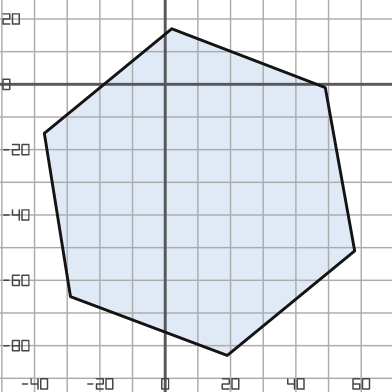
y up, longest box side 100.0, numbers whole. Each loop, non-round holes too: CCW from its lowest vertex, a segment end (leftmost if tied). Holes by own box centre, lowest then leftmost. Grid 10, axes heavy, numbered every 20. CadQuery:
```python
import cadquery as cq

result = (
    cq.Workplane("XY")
    .moveTo(19.0, -83.0)
    .lineTo(58.0, -51.0)
    .lineTo(49.0, -1.0)
    .lineTo(2.0, 17.0)
    .lineTo(-37.0, -15.0)
    .lineTo(-29.0, -65.0)
    .close()
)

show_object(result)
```